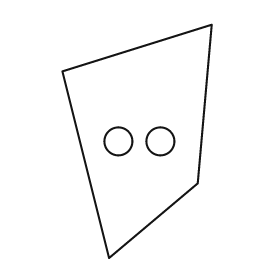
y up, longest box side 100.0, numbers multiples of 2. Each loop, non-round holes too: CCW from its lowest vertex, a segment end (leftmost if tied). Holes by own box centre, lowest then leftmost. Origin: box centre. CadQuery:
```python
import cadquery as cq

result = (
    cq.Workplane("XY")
    .moveTo(-12.0, -50.0)
    .lineTo(26.0, -18.0)
    .lineTo(32.0, 50.0)
    .lineTo(-32.0, 30.0)
    .close()
    .moveTo(-8.0, 0.0)
    .circle(6.0)
    .moveTo(10.0, 0.0)
    .circle(6.0)
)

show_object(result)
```